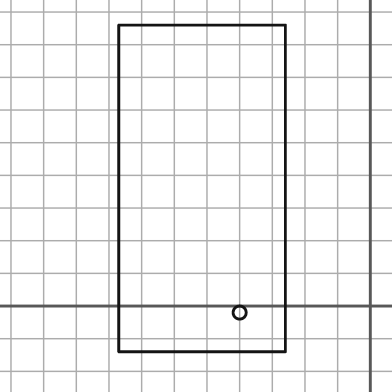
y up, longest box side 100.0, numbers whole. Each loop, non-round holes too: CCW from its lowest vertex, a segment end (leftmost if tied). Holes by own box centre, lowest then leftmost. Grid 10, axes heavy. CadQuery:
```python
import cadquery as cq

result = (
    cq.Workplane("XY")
    .moveTo(-77.0, -14.0)
    .lineTo(-26.0, -14.0)
    .lineTo(-26.0, 86.0)
    .lineTo(-77.0, 86.0)
    .close()
    .moveTo(-40.0, -2.0)
    .circle(2.0)
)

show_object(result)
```